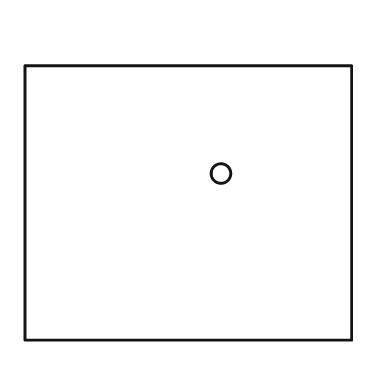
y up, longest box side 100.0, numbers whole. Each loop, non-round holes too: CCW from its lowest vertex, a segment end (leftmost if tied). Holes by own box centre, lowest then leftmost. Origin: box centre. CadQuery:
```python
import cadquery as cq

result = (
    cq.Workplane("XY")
    .moveTo(-50.0, -42.0)
    .lineTo(50.0, -42.0)
    .lineTo(50.0, 42.0)
    .lineTo(-50.0, 42.0)
    .close()
    .moveTo(10.0, 9.0)
    .circle(3.0)
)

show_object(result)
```